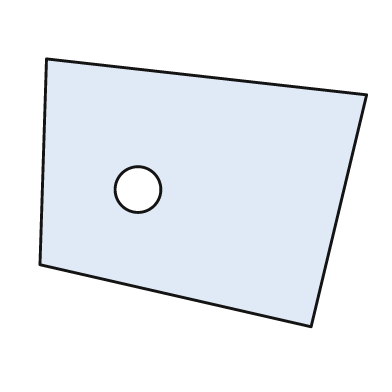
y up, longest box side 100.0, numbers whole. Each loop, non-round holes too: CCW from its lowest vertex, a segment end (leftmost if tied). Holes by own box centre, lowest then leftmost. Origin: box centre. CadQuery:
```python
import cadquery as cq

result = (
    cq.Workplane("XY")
    .moveTo(33.0, -41.0)
    .lineTo(50.0, 30.0)
    .lineTo(-48.0, 41.0)
    .lineTo(-50.0, -22.0)
    .close()
    .moveTo(-20.0, 1.0)
    .circle(7.0)
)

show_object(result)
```